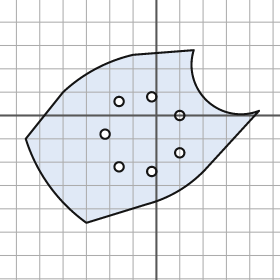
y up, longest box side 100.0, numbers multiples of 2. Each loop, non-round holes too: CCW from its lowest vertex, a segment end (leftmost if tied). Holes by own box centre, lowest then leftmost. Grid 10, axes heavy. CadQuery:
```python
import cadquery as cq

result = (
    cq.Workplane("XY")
    .moveTo(-30.0, -46.0)
    .lineTo(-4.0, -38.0)
    .threePointArc((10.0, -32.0), (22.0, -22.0))
    .lineTo(44.0, 2.0)
    .threePointArc((22.0, 6.0), (16.0, 28.0))
    .lineTo(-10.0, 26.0)
    .threePointArc((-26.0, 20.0), (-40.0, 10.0))
    .lineTo(-56.0, -10.0)
    .threePointArc((-46.0, -30.0), (-30.0, -46.0))
    .close()
    .moveTo(-2.0, -24.0)
    .circle(2.0)
    .moveTo(-16.0, -22.0)
    .circle(2.0)
    .moveTo(10.0, -16.0)
    .circle(2.0)
    .moveTo(-22.0, -8.0)
    .circle(2.0)
    .moveTo(10.0, 0.0)
    .circle(2.0)
    .moveTo(-16.0, 6.0)
    .circle(2.0)
    .moveTo(-2.0, 8.0)
    .circle(2.0)
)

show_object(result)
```